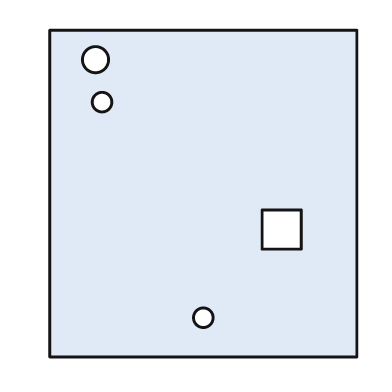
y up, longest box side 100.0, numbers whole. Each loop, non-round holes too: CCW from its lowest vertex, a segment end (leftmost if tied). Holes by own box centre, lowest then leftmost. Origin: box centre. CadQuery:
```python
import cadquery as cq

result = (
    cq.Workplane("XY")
    .moveTo(-47.0, -50.0)
    .lineTo(47.0, -50.0)
    .lineTo(47.0, 50.0)
    .lineTo(-47.0, 50.0)
    .close()
    .moveTo(0.0, -38.0)
    .circle(3.0)
    .moveTo(18.0, -17.0)
    .lineTo(30.0, -17.0)
    .lineTo(30.0, -5.0)
    .lineTo(18.0, -5.0)
    .close()
    .moveTo(-31.0, 28.0)
    .circle(3.0)
    .moveTo(-33.0, 41.0)
    .circle(4.0)
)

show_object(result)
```